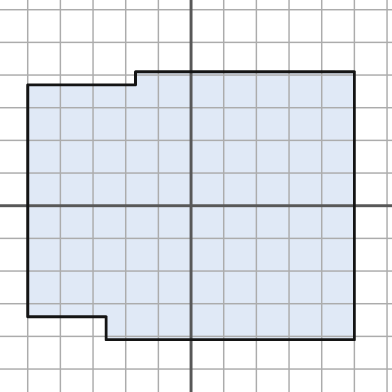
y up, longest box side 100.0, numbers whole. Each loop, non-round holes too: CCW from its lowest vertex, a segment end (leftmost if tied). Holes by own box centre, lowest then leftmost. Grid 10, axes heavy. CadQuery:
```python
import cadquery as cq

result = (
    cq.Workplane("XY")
    .moveTo(-26.0, -41.0)
    .lineTo(50.0, -41.0)
    .lineTo(50.0, 41.0)
    .lineTo(-17.0, 41.0)
    .lineTo(-17.0, 37.0)
    .lineTo(-50.0, 37.0)
    .lineTo(-50.0, -34.0)
    .lineTo(-26.0, -34.0)
    .close()
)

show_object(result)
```